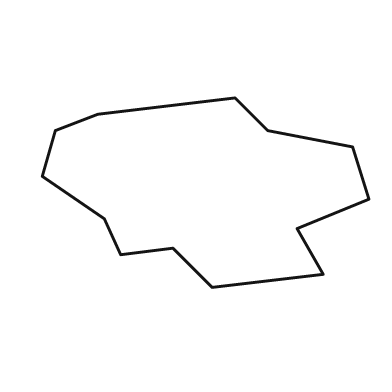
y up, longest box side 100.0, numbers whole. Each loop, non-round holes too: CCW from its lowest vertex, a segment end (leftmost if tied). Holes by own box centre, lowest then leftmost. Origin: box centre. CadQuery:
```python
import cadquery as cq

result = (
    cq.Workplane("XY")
    .moveTo(2.0, -29.0)
    .lineTo(36.0, -25.0)
    .lineTo(28.0, -11.0)
    .lineTo(50.0, -2.0)
    .lineTo(45.0, 14.0)
    .lineTo(19.0, 19.0)
    .lineTo(9.0, 29.0)
    .lineTo(-33.0, 24.0)
    .lineTo(-46.0, 19.0)
    .lineTo(-50.0, 5.0)
    .lineTo(-31.0, -8.0)
    .lineTo(-26.0, -19.0)
    .lineTo(-10.0, -17.0)
    .close()
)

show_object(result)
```